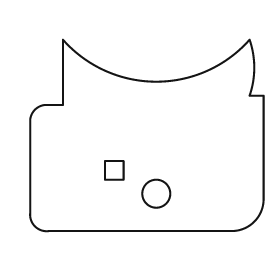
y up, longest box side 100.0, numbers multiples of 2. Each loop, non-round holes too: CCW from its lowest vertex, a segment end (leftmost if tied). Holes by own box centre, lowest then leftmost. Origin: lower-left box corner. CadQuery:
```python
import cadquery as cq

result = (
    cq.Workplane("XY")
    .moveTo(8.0, 0.0)
    .lineTo(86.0, 0.0)
    .threePointArc((96.0, 4.0), (100.0, 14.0))
    .lineTo(100.0, 58.0)
    .lineTo(94.0, 58.0)
    .threePointArc((96.0, 70.0), (94.0, 82.0))
    .threePointArc((54.0, 64.0), (14.0, 82.0))
    .lineTo(14.0, 54.0)
    .lineTo(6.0, 54.0)
    .threePointArc((2.0, 52.0), (0.0, 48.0))
    .lineTo(0.0, 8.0)
    .threePointArc((2.0, 2.0), (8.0, 0.0))
    .close()
    .moveTo(54.0, 16.0)
    .circle(6.0)
    .moveTo(32.0, 22.0)
    .lineTo(40.0, 22.0)
    .lineTo(40.0, 30.0)
    .lineTo(32.0, 30.0)
    .close()
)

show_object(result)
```